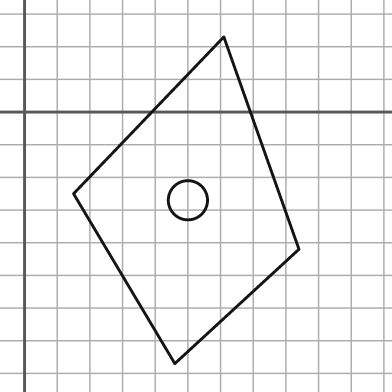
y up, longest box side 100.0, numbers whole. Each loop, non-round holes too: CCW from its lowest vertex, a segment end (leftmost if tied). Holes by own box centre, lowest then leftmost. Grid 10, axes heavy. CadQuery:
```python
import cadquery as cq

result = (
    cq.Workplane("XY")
    .moveTo(46.0, -77.0)
    .lineTo(84.0, -42.0)
    .lineTo(61.0, 23.0)
    .lineTo(15.0, -25.0)
    .close()
    .moveTo(50.0, -27.0)
    .circle(6.0)
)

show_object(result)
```